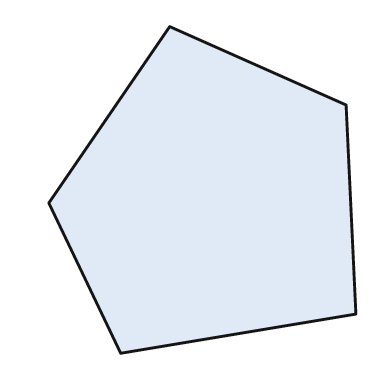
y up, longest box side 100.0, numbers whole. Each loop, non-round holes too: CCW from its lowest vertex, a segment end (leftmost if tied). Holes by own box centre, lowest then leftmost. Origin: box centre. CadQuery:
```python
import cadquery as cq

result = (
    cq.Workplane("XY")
    .moveTo(-25.0, -50.0)
    .lineTo(47.0, -38.0)
    .lineTo(44.0, 26.0)
    .lineTo(-10.0, 50.0)
    .lineTo(-47.0, -4.0)
    .close()
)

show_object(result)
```